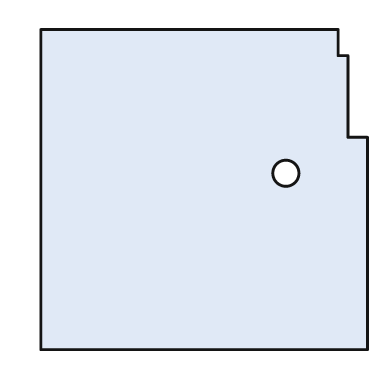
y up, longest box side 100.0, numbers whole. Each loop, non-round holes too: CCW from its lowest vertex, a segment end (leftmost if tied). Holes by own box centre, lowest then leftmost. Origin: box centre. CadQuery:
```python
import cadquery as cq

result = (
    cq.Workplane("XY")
    .moveTo(-50.0, -49.0)
    .lineTo(50.0, -49.0)
    .lineTo(50.0, 16.0)
    .lineTo(44.0, 16.0)
    .lineTo(44.0, 41.0)
    .lineTo(41.0, 41.0)
    .lineTo(41.0, 49.0)
    .lineTo(-50.0, 49.0)
    .close()
    .moveTo(25.0, 5.0)
    .circle(4.0)
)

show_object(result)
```